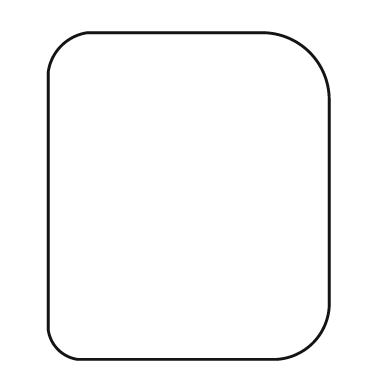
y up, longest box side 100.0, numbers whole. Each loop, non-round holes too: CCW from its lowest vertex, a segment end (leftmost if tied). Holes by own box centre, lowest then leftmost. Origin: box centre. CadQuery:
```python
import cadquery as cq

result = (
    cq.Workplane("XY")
    .moveTo(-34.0, -50.0)
    .lineTo(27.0, -50.0)
    .threePointArc((38.0, -45.0), (43.0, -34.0))
    .lineTo(43.0, 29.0)
    .threePointArc((37.0, 44.0), (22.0, 50.0))
    .lineTo(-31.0, 50.0)
    .threePointArc((-39.0, 46.0), (-43.0, 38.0))
    .lineTo(-43.0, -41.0)
    .threePointArc((-40.0, -47.0), (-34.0, -50.0))
    .close()
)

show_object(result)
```